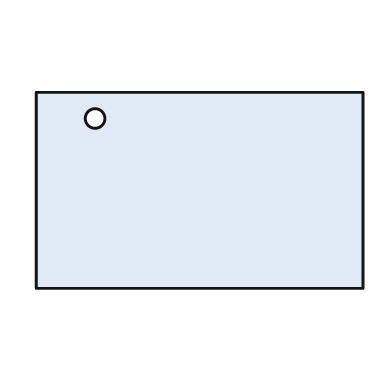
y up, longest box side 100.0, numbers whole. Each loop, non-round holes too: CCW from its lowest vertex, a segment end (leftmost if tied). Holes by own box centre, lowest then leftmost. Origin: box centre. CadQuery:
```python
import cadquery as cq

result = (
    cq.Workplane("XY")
    .moveTo(-50.0, -30.0)
    .lineTo(50.0, -30.0)
    .lineTo(50.0, 30.0)
    .lineTo(-50.0, 30.0)
    .close()
    .moveTo(-32.0, 22.0)
    .circle(3.0)
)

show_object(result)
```